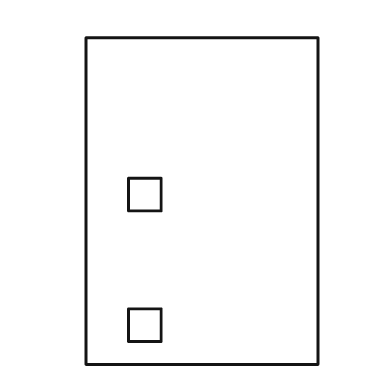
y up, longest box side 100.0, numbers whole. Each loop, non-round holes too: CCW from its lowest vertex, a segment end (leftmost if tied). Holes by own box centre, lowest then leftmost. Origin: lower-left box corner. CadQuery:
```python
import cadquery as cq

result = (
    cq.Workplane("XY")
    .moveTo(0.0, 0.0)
    .lineTo(71.0, 0.0)
    .lineTo(71.0, 100.0)
    .lineTo(0.0, 100.0)
    .close()
    .moveTo(13.0, 7.0)
    .lineTo(23.0, 7.0)
    .lineTo(23.0, 17.0)
    .lineTo(13.0, 17.0)
    .close()
    .moveTo(13.0, 47.0)
    .lineTo(23.0, 47.0)
    .lineTo(23.0, 57.0)
    .lineTo(13.0, 57.0)
    .close()
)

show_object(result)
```